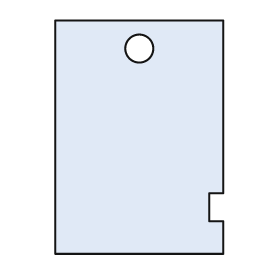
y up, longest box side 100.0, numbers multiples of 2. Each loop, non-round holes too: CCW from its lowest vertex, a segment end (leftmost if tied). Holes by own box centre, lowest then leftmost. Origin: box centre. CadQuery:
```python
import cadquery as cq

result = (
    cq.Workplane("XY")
    .moveTo(-36.0, -50.0)
    .lineTo(36.0, -50.0)
    .lineTo(36.0, -36.0)
    .lineTo(30.0, -36.0)
    .lineTo(30.0, -24.0)
    .lineTo(36.0, -24.0)
    .lineTo(36.0, 50.0)
    .lineTo(-36.0, 50.0)
    .close()
    .moveTo(0.0, 38.0)
    .circle(6.0)
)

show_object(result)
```